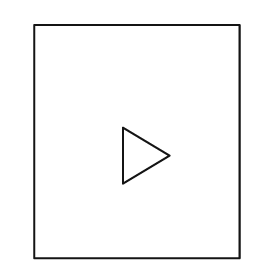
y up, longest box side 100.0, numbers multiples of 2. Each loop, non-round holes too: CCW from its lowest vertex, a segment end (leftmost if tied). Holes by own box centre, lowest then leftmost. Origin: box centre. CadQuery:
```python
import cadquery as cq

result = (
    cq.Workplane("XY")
    .moveTo(-44.0, -50.0)
    .lineTo(44.0, -50.0)
    .lineTo(44.0, 50.0)
    .lineTo(-44.0, 50.0)
    .close()
    .moveTo(-6.0, -18.0)
    .lineTo(14.0, -6.0)
    .lineTo(-6.0, 6.0)
    .close()
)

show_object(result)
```